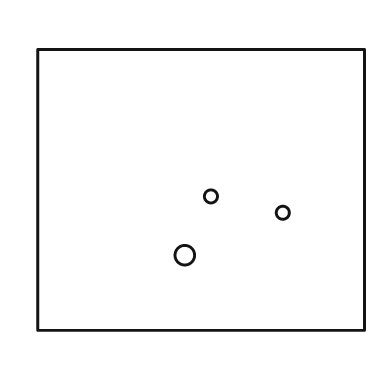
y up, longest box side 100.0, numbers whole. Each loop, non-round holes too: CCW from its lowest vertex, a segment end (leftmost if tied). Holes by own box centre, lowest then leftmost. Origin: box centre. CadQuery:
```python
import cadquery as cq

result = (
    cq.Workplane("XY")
    .moveTo(-50.0, -43.0)
    .lineTo(50.0, -43.0)
    .lineTo(50.0, 43.0)
    .lineTo(-50.0, 43.0)
    .close()
    .moveTo(-5.0, -20.0)
    .circle(3.0)
    .moveTo(25.0, -7.0)
    .circle(2.0)
    .moveTo(3.0, -2.0)
    .circle(2.0)
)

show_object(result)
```